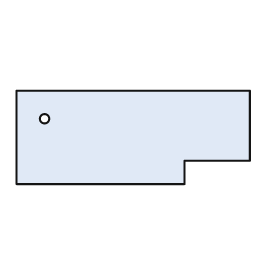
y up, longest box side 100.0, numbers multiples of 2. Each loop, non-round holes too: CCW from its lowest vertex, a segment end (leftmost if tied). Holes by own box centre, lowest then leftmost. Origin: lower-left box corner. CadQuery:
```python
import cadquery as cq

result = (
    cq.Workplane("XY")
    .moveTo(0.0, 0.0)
    .lineTo(72.0, 0.0)
    .lineTo(72.0, 10.0)
    .lineTo(100.0, 10.0)
    .lineTo(100.0, 40.0)
    .lineTo(0.0, 40.0)
    .close()
    .moveTo(12.0, 28.0)
    .circle(2.0)
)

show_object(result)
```